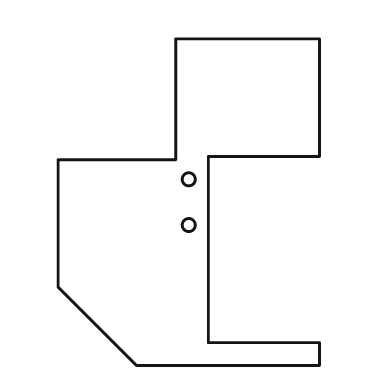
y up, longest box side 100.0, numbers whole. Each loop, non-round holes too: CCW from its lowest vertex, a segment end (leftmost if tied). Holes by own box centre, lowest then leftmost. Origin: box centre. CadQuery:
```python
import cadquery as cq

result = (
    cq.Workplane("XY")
    .moveTo(-16.0, -50.0)
    .lineTo(40.0, -50.0)
    .lineTo(40.0, -43.0)
    .lineTo(6.0, -43.0)
    .lineTo(6.0, 14.0)
    .lineTo(40.0, 14.0)
    .lineTo(40.0, 50.0)
    .lineTo(-4.0, 50.0)
    .lineTo(-4.0, 13.0)
    .lineTo(-40.0, 13.0)
    .lineTo(-40.0, -26.0)
    .close()
    .moveTo(0.0, -7.0)
    .circle(2.0)
    .moveTo(0.0, 7.0)
    .circle(2.0)
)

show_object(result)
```